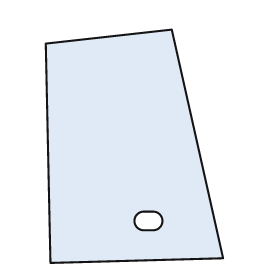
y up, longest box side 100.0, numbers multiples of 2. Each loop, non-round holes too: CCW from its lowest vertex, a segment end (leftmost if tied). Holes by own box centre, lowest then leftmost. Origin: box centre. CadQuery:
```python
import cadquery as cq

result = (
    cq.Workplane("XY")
    .moveTo(-36.0, -50.0)
    .lineTo(38.0, -48.0)
    .lineTo(16.0, 50.0)
    .lineTo(-38.0, 44.0)
    .close()
    .moveTo(4.0, -36.0)
    .lineTo(8.0, -36.0)
    .threePointArc((12.0, -32.0), (8.0, -28.0))
    .lineTo(4.0, -28.0)
    .threePointArc((0.0, -32.0), (4.0, -36.0))
    .close()
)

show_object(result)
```